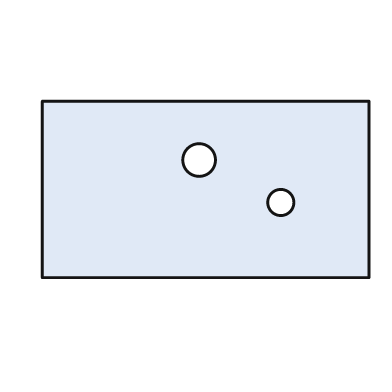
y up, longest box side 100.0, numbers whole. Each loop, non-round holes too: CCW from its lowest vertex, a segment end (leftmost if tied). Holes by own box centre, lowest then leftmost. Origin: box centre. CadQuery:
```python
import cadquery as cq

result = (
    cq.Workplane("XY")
    .moveTo(-50.0, -27.0)
    .lineTo(50.0, -27.0)
    .lineTo(50.0, 27.0)
    .lineTo(-50.0, 27.0)
    .close()
    .moveTo(23.0, -4.0)
    .circle(4.0)
    .moveTo(-2.0, 9.0)
    .circle(5.0)
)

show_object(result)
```